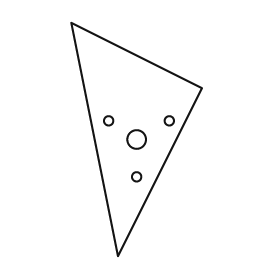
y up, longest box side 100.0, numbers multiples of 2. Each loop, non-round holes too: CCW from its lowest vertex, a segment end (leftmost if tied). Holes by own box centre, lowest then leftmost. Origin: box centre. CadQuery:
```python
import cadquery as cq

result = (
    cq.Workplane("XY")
    .moveTo(-8.0, -50.0)
    .lineTo(28.0, 22.0)
    .lineTo(-28.0, 50.0)
    .close()
    .moveTo(0.0, -16.0)
    .circle(2.0)
    .moveTo(0.0, 0.0)
    .circle(4.0)
    .moveTo(-12.0, 8.0)
    .circle(2.0)
    .moveTo(14.0, 8.0)
    .circle(2.0)
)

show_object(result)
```